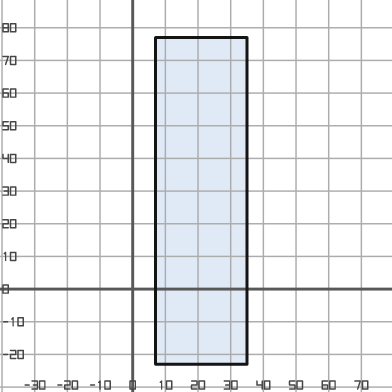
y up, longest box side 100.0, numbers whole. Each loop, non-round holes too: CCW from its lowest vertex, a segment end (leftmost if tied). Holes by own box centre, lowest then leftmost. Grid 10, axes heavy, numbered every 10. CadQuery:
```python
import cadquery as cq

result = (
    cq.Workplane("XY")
    .moveTo(7.0, -23.0)
    .lineTo(35.0, -23.0)
    .lineTo(35.0, 77.0)
    .lineTo(7.0, 77.0)
    .close()
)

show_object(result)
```